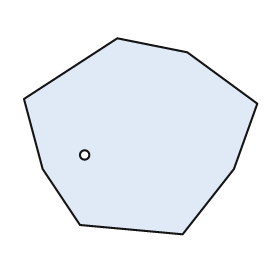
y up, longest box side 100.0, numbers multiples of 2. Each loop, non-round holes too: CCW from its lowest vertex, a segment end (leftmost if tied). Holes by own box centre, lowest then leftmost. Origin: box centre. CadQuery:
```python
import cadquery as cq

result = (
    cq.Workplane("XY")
    .moveTo(18.0, -42.0)
    .lineTo(40.0, -14.0)
    .lineTo(50.0, 14.0)
    .lineTo(20.0, 36.0)
    .lineTo(-10.0, 42.0)
    .lineTo(-50.0, 16.0)
    .lineTo(-42.0, -14.0)
    .lineTo(-26.0, -38.0)
    .close()
    .moveTo(-24.0, -8.0)
    .circle(2.0)
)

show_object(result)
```